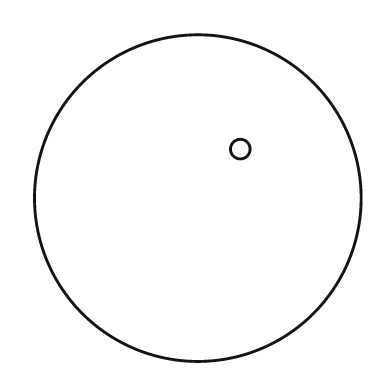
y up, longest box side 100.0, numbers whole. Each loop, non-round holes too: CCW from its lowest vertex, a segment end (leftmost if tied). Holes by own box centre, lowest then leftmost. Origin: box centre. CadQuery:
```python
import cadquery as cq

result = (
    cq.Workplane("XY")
    .moveTo(0.0, 0.0)
    .circle(50.0)
    .moveTo(13.0, 15.0)
    .circle(3.0)
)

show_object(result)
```